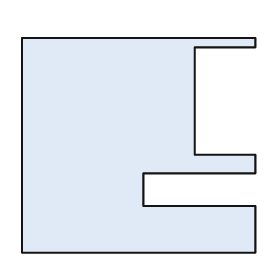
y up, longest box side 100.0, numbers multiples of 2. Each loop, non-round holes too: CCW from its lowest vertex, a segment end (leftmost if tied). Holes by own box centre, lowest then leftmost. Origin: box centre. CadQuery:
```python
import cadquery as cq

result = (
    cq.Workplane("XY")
    .moveTo(-50.0, -46.0)
    .lineTo(50.0, -46.0)
    .lineTo(50.0, -26.0)
    .lineTo(2.0, -26.0)
    .lineTo(2.0, -12.0)
    .lineTo(50.0, -12.0)
    .lineTo(50.0, -4.0)
    .lineTo(24.0, -4.0)
    .lineTo(24.0, 42.0)
    .lineTo(50.0, 42.0)
    .lineTo(50.0, 46.0)
    .lineTo(-50.0, 46.0)
    .close()
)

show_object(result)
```